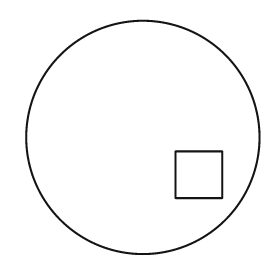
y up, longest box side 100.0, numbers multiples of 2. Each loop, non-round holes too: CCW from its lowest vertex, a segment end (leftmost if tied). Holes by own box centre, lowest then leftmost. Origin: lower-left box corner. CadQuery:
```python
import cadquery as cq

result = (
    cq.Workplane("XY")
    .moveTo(50.0, 50.0)
    .circle(50.0)
    .moveTo(64.0, 24.0)
    .lineTo(84.0, 24.0)
    .lineTo(84.0, 44.0)
    .lineTo(64.0, 44.0)
    .close()
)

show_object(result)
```